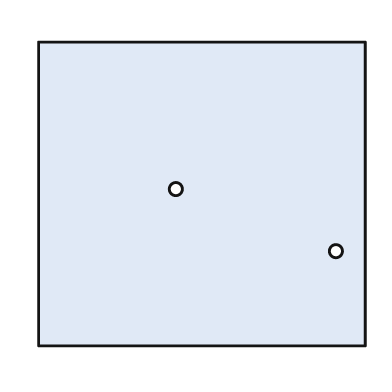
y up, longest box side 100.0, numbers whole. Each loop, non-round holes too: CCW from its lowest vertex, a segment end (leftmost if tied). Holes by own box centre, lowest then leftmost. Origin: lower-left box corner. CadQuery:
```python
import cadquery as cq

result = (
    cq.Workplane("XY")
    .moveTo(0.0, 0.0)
    .lineTo(100.0, 0.0)
    .lineTo(100.0, 93.0)
    .lineTo(0.0, 93.0)
    .close()
    .moveTo(91.0, 29.0)
    .circle(2.0)
    .moveTo(42.0, 48.0)
    .circle(2.0)
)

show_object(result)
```